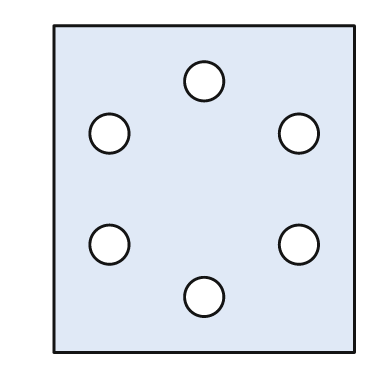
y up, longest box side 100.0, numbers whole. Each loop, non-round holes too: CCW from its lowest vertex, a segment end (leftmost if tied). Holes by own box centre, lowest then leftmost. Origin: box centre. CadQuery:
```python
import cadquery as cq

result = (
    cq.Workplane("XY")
    .moveTo(-46.0, -50.0)
    .lineTo(46.0, -50.0)
    .lineTo(46.0, 50.0)
    .lineTo(-46.0, 50.0)
    .close()
    .moveTo(0.0, -33.0)
    .circle(6.0)
    .moveTo(-29.0, -17.0)
    .circle(6.0)
    .moveTo(29.0, -17.0)
    .circle(6.0)
    .moveTo(-29.0, 17.0)
    .circle(6.0)
    .moveTo(29.0, 17.0)
    .circle(6.0)
    .moveTo(0.0, 33.0)
    .circle(6.0)
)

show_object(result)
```